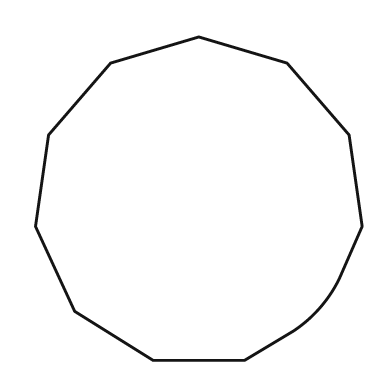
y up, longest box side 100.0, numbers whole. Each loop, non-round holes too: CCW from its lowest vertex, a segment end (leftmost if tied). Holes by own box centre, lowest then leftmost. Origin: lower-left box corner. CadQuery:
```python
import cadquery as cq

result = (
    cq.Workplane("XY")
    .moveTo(36.0, 0.0)
    .lineTo(64.0, 0.0)
    .lineTo(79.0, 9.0)
    .threePointArc((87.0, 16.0), (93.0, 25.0))
    .lineTo(100.0, 41.0)
    .lineTo(96.0, 69.0)
    .lineTo(77.0, 91.0)
    .lineTo(50.0, 99.0)
    .lineTo(23.0, 91.0)
    .lineTo(4.0, 69.0)
    .lineTo(0.0, 41.0)
    .lineTo(12.0, 15.0)
    .close()
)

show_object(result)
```